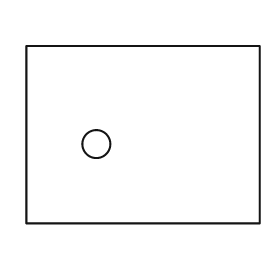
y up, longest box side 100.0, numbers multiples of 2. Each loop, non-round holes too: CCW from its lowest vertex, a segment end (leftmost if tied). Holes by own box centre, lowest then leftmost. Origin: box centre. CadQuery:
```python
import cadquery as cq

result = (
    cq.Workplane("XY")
    .moveTo(-50.0, -38.0)
    .lineTo(50.0, -38.0)
    .lineTo(50.0, 38.0)
    .lineTo(-50.0, 38.0)
    .close()
    .moveTo(-20.0, -4.0)
    .circle(6.0)
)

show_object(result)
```